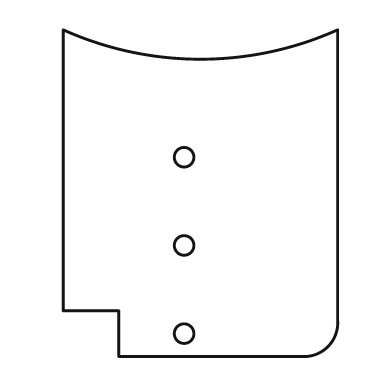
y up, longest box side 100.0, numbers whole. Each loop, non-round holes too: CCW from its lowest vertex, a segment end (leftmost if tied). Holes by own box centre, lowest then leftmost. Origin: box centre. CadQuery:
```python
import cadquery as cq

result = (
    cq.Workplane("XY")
    .moveTo(-25.0, -50.0)
    .lineTo(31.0, -50.0)
    .threePointArc((39.0, -47.0), (42.0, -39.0))
    .lineTo(42.0, 50.0)
    .threePointArc((0.0, 41.0), (-42.0, 50.0))
    .lineTo(-42.0, -36.0)
    .lineTo(-25.0, -36.0)
    .close()
    .moveTo(-5.0, -43.0)
    .circle(3.0)
    .moveTo(-5.0, -16.0)
    .circle(3.0)
    .moveTo(-5.0, 11.0)
    .circle(3.0)
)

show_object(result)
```